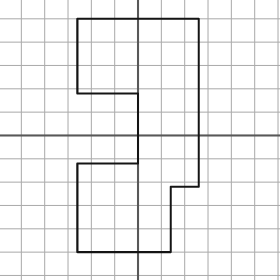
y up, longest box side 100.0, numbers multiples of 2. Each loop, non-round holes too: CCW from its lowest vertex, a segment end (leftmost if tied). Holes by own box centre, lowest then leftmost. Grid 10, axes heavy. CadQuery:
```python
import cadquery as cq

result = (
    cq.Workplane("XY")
    .moveTo(-26.0, -50.0)
    .lineTo(14.0, -50.0)
    .lineTo(14.0, -22.0)
    .lineTo(26.0, -22.0)
    .lineTo(26.0, 50.0)
    .lineTo(-26.0, 50.0)
    .lineTo(-26.0, 18.0)
    .lineTo(0.0, 18.0)
    .lineTo(0.0, -12.0)
    .lineTo(-26.0, -12.0)
    .close()
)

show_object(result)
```